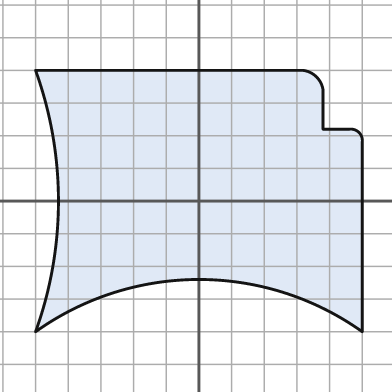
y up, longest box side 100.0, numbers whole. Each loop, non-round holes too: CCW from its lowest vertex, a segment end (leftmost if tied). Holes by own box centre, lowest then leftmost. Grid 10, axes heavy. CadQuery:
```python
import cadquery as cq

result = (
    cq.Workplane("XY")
    .moveTo(-50.0, -40.0)
    .threePointArc((0.0, -24.0), (50.0, -40.0))
    .lineTo(50.0, 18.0)
    .threePointArc((49.0, 21.0), (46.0, 22.0))
    .lineTo(38.0, 22.0)
    .lineTo(38.0, 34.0)
    .threePointArc((36.0, 38.0), (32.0, 40.0))
    .lineTo(-50.0, 40.0)
    .threePointArc((-43.0, 0.0), (-50.0, -40.0))
    .close()
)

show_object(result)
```